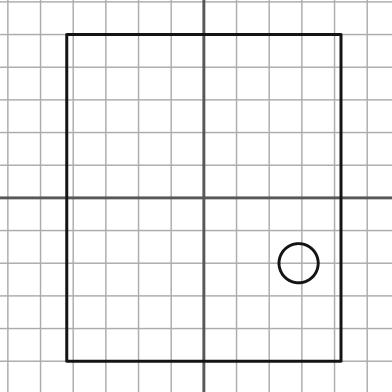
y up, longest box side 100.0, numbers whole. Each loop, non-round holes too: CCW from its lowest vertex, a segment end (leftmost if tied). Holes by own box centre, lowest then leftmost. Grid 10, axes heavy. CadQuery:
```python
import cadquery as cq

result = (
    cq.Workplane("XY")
    .moveTo(-42.0, -50.0)
    .lineTo(42.0, -50.0)
    .lineTo(42.0, 50.0)
    .lineTo(-42.0, 50.0)
    .close()
    .moveTo(29.0, -20.0)
    .circle(6.0)
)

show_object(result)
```